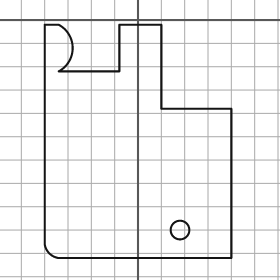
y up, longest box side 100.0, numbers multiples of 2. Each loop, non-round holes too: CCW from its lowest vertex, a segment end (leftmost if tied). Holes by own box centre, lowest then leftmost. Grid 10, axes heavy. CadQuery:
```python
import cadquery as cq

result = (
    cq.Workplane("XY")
    .moveTo(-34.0, -102.0)
    .lineTo(40.0, -102.0)
    .lineTo(40.0, -38.0)
    .lineTo(10.0, -38.0)
    .lineTo(10.0, -2.0)
    .lineTo(-8.0, -2.0)
    .lineTo(-8.0, -22.0)
    .lineTo(-34.0, -22.0)
    .threePointArc((-28.0, -12.0), (-34.0, -2.0))
    .lineTo(-40.0, -2.0)
    .lineTo(-40.0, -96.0)
    .threePointArc((-38.0, -100.0), (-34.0, -102.0))
    .close()
    .moveTo(18.0, -90.0)
    .circle(4.0)
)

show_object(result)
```